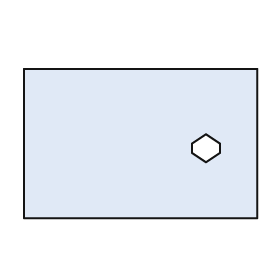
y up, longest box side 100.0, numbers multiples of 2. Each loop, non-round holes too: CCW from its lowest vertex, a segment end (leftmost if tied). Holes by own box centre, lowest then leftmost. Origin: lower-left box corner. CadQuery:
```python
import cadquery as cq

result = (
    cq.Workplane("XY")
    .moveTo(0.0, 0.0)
    .lineTo(100.0, 0.0)
    .lineTo(100.0, 64.0)
    .lineTo(0.0, 64.0)
    .close()
    .moveTo(78.0, 24.0)
    .lineTo(84.0, 28.0)
    .lineTo(84.0, 32.0)
    .lineTo(78.0, 36.0)
    .lineTo(72.0, 32.0)
    .lineTo(72.0, 28.0)
    .close()
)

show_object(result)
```